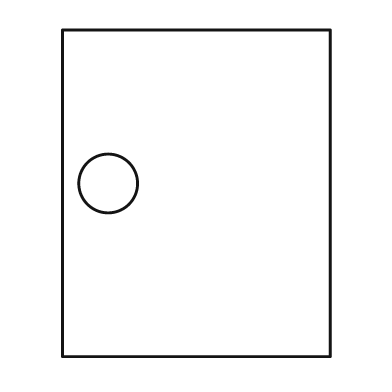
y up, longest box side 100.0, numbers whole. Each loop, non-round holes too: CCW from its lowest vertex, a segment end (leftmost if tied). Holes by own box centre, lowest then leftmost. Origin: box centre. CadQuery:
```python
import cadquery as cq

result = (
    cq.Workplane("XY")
    .moveTo(-41.0, -50.0)
    .lineTo(41.0, -50.0)
    .lineTo(41.0, 50.0)
    .lineTo(-41.0, 50.0)
    .close()
    .moveTo(-27.0, 3.0)
    .circle(9.0)
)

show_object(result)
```